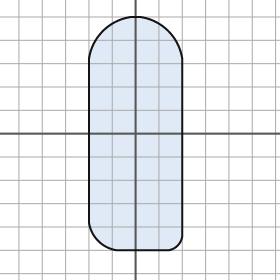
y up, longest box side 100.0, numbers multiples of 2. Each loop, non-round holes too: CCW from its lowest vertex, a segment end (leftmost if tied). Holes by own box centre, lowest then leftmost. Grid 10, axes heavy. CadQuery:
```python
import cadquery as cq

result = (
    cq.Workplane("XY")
    .moveTo(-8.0, -50.0)
    .lineTo(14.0, -50.0)
    .threePointArc((18.0, -48.0), (20.0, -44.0))
    .lineTo(20.0, 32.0)
    .threePointArc((14.0, 44.0), (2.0, 50.0))
    .lineTo(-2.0, 50.0)
    .threePointArc((-14.0, 44.0), (-20.0, 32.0))
    .lineTo(-20.0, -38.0)
    .threePointArc((-16.0, -46.0), (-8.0, -50.0))
    .close()
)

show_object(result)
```